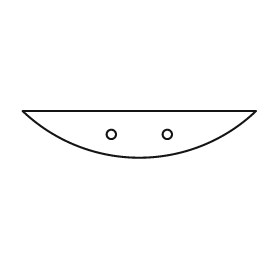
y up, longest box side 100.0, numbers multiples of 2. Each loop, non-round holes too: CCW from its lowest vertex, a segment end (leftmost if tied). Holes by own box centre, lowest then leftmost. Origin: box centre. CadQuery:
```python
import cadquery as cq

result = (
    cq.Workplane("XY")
    .moveTo(-50.0, 10.0)
    .threePointArc((0.0, -10.0), (50.0, 10.0))
    .close()
    .moveTo(-12.0, 0.0)
    .circle(2.0)
    .moveTo(12.0, 0.0)
    .circle(2.0)
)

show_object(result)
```